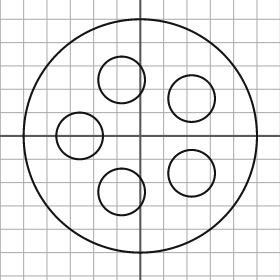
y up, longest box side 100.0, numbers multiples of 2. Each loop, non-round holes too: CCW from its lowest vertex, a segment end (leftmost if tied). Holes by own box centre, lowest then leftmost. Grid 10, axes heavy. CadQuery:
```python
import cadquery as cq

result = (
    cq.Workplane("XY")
    .moveTo(0.0, 0.0)
    .circle(50.0)
    .moveTo(-8.0, -24.0)
    .circle(10.0)
    .moveTo(22.0, -16.0)
    .circle(10.0)
    .moveTo(-26.0, 0.0)
    .circle(10.0)
    .moveTo(22.0, 16.0)
    .circle(10.0)
    .moveTo(-8.0, 24.0)
    .circle(10.0)
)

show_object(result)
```